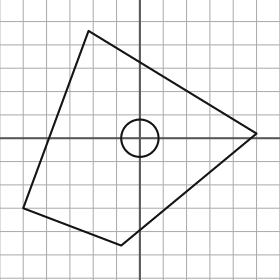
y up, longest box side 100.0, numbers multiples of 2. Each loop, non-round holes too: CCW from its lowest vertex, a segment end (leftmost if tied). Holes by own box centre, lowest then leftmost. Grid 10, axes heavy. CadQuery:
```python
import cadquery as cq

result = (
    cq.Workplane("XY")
    .moveTo(-8.0, -46.0)
    .lineTo(50.0, 2.0)
    .lineTo(-22.0, 46.0)
    .lineTo(-50.0, -30.0)
    .close()
    .moveTo(0.0, 0.0)
    .circle(8.0)
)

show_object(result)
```